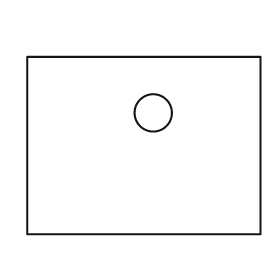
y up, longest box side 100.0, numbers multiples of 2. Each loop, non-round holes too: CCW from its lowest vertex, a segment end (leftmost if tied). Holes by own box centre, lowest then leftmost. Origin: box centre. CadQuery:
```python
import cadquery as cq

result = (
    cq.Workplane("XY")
    .moveTo(-50.0, -38.0)
    .lineTo(50.0, -38.0)
    .lineTo(50.0, 38.0)
    .lineTo(-50.0, 38.0)
    .close()
    .moveTo(4.0, 14.0)
    .circle(8.0)
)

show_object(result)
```